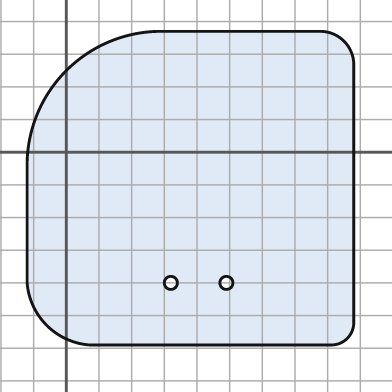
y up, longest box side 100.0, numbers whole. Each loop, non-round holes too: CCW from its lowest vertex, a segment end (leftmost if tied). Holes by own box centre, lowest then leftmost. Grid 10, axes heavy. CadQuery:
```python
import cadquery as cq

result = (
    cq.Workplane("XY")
    .moveTo(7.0, -59.0)
    .lineTo(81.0, -59.0)
    .threePointArc((86.0, -57.0), (88.0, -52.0))
    .lineTo(88.0, 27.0)
    .threePointArc((85.0, 34.0), (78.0, 37.0))
    .lineTo(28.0, 37.0)
    .threePointArc((0.0, 25.0), (-12.0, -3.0))
    .lineTo(-12.0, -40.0)
    .threePointArc((-6.0, -53.0), (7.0, -59.0))
    .close()
    .moveTo(32.0, -40.0)
    .circle(2.0)
    .moveTo(49.0, -40.0)
    .circle(2.0)
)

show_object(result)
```